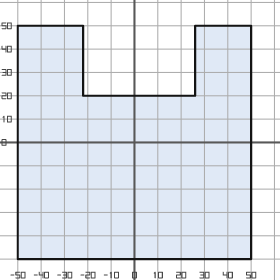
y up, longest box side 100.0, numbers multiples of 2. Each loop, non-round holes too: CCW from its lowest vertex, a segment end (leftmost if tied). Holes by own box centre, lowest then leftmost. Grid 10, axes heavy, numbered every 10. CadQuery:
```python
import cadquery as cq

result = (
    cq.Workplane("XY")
    .moveTo(-50.0, -50.0)
    .lineTo(50.0, -50.0)
    .lineTo(50.0, 50.0)
    .lineTo(26.0, 50.0)
    .lineTo(26.0, 20.0)
    .lineTo(-22.0, 20.0)
    .lineTo(-22.0, 50.0)
    .lineTo(-50.0, 50.0)
    .close()
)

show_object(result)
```